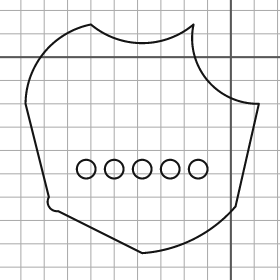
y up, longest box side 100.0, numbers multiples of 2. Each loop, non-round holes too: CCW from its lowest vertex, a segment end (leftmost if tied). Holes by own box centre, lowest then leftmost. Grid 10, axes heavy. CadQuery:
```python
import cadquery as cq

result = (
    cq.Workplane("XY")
    .moveTo(-38.0, -84.0)
    .threePointArc((-16.0, -78.0), (2.0, -64.0))
    .lineTo(12.0, -20.0)
    .threePointArc((-10.0, -10.0), (-16.0, 14.0))
    .threePointArc((-38.0, 6.0), (-60.0, 14.0))
    .threePointArc((-80.0, 2.0), (-88.0, -20.0))
    .lineTo(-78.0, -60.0)
    .threePointArc((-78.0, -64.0), (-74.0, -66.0))
    .close()
    .moveTo(-62.0, -48.0)
    .circle(4.0)
    .moveTo(-50.0, -48.0)
    .circle(4.0)
    .moveTo(-38.0, -48.0)
    .circle(4.0)
    .moveTo(-26.0, -48.0)
    .circle(4.0)
    .moveTo(-14.0, -48.0)
    .circle(4.0)
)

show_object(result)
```